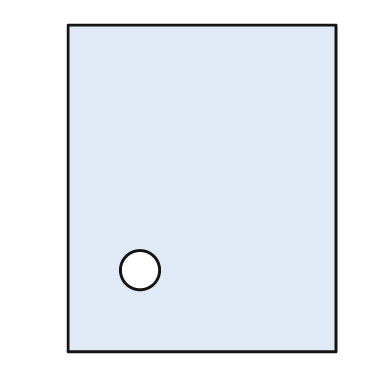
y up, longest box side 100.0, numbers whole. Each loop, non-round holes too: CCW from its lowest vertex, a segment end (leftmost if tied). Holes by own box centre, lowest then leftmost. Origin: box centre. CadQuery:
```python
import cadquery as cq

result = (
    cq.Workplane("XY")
    .moveTo(-41.0, -50.0)
    .lineTo(41.0, -50.0)
    .lineTo(41.0, 50.0)
    .lineTo(-41.0, 50.0)
    .close()
    .moveTo(-19.0, -25.0)
    .circle(6.0)
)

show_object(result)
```